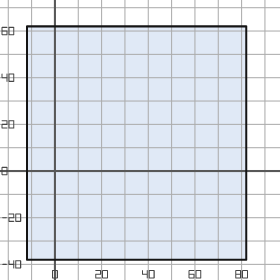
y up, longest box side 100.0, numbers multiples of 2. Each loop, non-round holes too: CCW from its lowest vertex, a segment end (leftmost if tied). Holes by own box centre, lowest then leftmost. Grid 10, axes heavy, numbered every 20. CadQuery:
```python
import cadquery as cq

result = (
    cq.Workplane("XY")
    .moveTo(-12.0, -38.0)
    .lineTo(82.0, -38.0)
    .lineTo(82.0, 62.0)
    .lineTo(-12.0, 62.0)
    .close()
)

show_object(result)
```